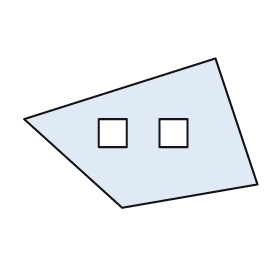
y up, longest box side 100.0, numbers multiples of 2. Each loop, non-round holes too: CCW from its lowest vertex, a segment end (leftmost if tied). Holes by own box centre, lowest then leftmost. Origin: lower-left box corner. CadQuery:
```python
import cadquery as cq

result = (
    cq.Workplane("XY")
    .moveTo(42.0, 0.0)
    .lineTo(100.0, 10.0)
    .lineTo(82.0, 64.0)
    .lineTo(0.0, 38.0)
    .close()
    .moveTo(32.0, 26.0)
    .lineTo(44.0, 26.0)
    .lineTo(44.0, 38.0)
    .lineTo(32.0, 38.0)
    .close()
    .moveTo(58.0, 26.0)
    .lineTo(70.0, 26.0)
    .lineTo(70.0, 38.0)
    .lineTo(58.0, 38.0)
    .close()
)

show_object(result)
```